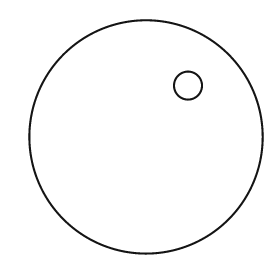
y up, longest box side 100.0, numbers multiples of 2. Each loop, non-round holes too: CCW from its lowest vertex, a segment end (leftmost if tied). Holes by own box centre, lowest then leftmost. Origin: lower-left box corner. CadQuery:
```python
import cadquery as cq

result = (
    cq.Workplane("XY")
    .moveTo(50.0, 50.0)
    .circle(50.0)
    .moveTo(68.0, 72.0)
    .circle(6.0)
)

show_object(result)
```